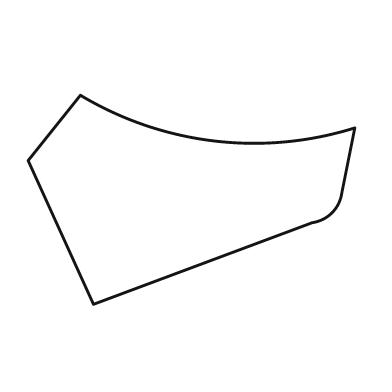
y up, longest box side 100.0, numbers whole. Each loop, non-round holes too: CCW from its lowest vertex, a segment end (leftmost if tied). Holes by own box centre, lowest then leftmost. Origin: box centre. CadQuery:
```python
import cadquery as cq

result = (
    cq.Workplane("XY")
    .moveTo(-30.0, -32.0)
    .lineTo(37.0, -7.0)
    .threePointArc((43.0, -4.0), (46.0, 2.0))
    .lineTo(50.0, 22.0)
    .threePointArc((7.0, 18.0), (-34.0, 32.0))
    .lineTo(-50.0, 12.0)
    .close()
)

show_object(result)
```